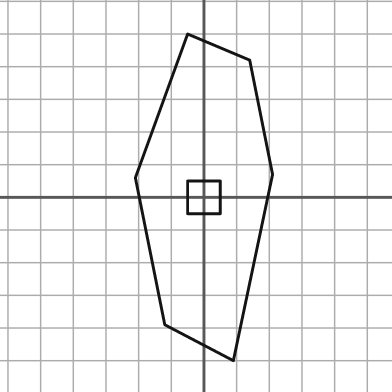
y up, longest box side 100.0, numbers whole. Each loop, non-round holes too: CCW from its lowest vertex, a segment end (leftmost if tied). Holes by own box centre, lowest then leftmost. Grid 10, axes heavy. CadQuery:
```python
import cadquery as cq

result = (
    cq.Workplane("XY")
    .moveTo(9.0, -50.0)
    .lineTo(21.0, 7.0)
    .lineTo(14.0, 42.0)
    .lineTo(-5.0, 50.0)
    .lineTo(-21.0, 6.0)
    .lineTo(-12.0, -39.0)
    .close()
    .moveTo(-5.0, -5.0)
    .lineTo(5.0, -5.0)
    .lineTo(5.0, 5.0)
    .lineTo(-5.0, 5.0)
    .close()
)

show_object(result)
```